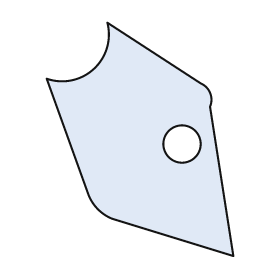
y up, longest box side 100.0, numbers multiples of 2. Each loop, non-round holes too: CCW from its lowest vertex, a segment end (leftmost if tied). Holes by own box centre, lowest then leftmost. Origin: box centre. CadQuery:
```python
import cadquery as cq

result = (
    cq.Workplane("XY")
    .moveTo(40.0, -50.0)
    .lineTo(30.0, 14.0)
    .threePointArc((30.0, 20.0), (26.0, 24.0))
    .lineTo(-14.0, 50.0)
    .threePointArc((-20.0, 30.0), (-40.0, 26.0))
    .lineTo(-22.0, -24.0)
    .threePointArc((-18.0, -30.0), (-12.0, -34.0))
    .close()
    .moveTo(18.0, -2.0)
    .circle(8.0)
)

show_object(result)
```